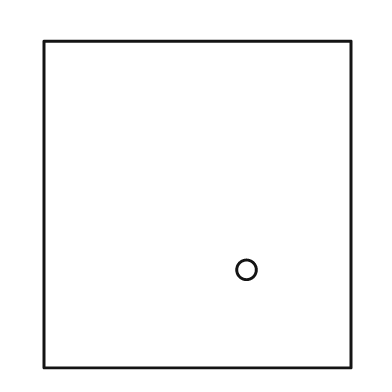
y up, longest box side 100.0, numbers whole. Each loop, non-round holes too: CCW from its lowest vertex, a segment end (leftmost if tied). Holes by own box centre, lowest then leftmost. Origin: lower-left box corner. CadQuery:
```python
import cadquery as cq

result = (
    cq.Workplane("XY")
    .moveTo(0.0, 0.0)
    .lineTo(94.0, 0.0)
    .lineTo(94.0, 100.0)
    .lineTo(0.0, 100.0)
    .close()
    .moveTo(62.0, 30.0)
    .circle(3.0)
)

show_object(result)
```